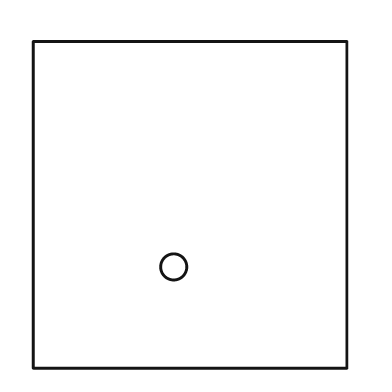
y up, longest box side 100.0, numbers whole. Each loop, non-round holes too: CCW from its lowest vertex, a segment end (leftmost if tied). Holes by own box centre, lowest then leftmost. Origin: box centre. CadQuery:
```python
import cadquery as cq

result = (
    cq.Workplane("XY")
    .moveTo(-48.0, -50.0)
    .lineTo(48.0, -50.0)
    .lineTo(48.0, 50.0)
    .lineTo(-48.0, 50.0)
    .close()
    .moveTo(-5.0, -19.0)
    .circle(4.0)
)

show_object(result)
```